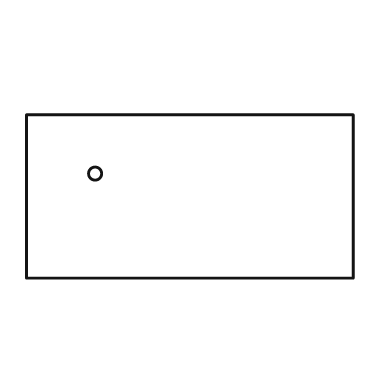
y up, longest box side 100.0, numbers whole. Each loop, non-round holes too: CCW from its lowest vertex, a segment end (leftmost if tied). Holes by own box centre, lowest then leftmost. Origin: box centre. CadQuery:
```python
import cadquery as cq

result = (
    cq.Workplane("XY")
    .moveTo(-50.0, -25.0)
    .lineTo(50.0, -25.0)
    .lineTo(50.0, 25.0)
    .lineTo(-50.0, 25.0)
    .close()
    .moveTo(-29.0, 7.0)
    .circle(2.0)
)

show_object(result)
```